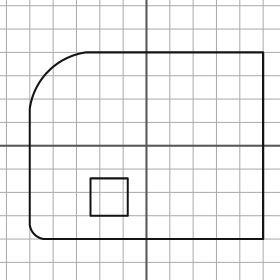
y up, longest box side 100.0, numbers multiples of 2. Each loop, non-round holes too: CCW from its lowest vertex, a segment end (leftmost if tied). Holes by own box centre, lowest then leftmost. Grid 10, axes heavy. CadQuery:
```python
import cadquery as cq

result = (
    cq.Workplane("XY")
    .moveTo(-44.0, -40.0)
    .lineTo(50.0, -40.0)
    .lineTo(50.0, 40.0)
    .lineTo(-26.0, 40.0)
    .threePointArc((-42.0, 32.0), (-50.0, 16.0))
    .lineTo(-50.0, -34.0)
    .threePointArc((-48.0, -38.0), (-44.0, -40.0))
    .close()
    .moveTo(-24.0, -30.0)
    .lineTo(-8.0, -30.0)
    .lineTo(-8.0, -14.0)
    .lineTo(-24.0, -14.0)
    .close()
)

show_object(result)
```